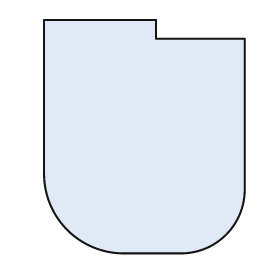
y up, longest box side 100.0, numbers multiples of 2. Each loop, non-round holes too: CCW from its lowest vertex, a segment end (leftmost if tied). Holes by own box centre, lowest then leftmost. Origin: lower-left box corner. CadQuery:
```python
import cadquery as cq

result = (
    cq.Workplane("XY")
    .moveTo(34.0, 0.0)
    .lineTo(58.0, 0.0)
    .threePointArc((78.0, 8.0), (86.0, 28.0))
    .lineTo(86.0, 92.0)
    .lineTo(48.0, 92.0)
    .lineTo(48.0, 100.0)
    .lineTo(0.0, 100.0)
    .lineTo(0.0, 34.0)
    .threePointArc((10.0, 10.0), (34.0, 0.0))
    .close()
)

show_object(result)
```